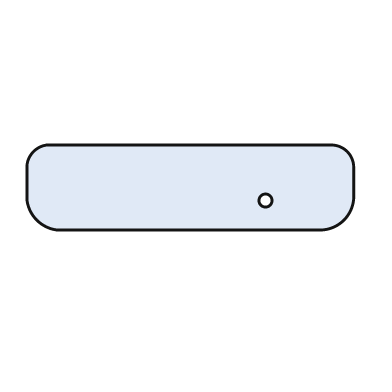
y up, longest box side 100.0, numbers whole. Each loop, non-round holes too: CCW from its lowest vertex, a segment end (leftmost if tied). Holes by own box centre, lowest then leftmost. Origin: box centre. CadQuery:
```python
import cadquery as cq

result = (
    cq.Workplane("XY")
    .moveTo(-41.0, -13.0)
    .lineTo(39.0, -13.0)
    .threePointArc((47.0, -10.0), (50.0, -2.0))
    .lineTo(50.0, 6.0)
    .threePointArc((48.0, 11.0), (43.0, 13.0))
    .lineTo(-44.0, 13.0)
    .threePointArc((-48.0, 11.0), (-50.0, 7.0))
    .lineTo(-50.0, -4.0)
    .threePointArc((-47.0, -10.0), (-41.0, -13.0))
    .close()
    .moveTo(23.0, -4.0)
    .circle(2.0)
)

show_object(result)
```